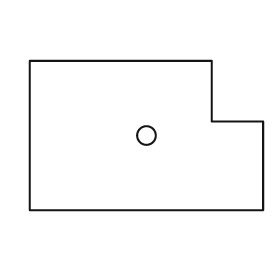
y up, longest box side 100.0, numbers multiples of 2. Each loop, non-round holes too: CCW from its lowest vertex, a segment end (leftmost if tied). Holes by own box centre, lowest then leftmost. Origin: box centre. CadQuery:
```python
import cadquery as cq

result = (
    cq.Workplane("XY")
    .moveTo(-50.0, -32.0)
    .lineTo(50.0, -32.0)
    .lineTo(50.0, 6.0)
    .lineTo(28.0, 6.0)
    .lineTo(28.0, 32.0)
    .lineTo(-50.0, 32.0)
    .close()
    .moveTo(0.0, 0.0)
    .circle(4.0)
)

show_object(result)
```